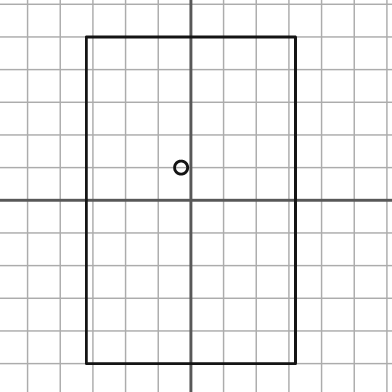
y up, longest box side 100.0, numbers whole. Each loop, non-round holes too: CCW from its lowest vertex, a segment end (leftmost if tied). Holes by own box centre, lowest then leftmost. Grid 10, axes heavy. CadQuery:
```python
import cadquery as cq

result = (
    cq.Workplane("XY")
    .moveTo(-32.0, -50.0)
    .lineTo(32.0, -50.0)
    .lineTo(32.0, 50.0)
    .lineTo(-32.0, 50.0)
    .close()
    .moveTo(-3.0, 10.0)
    .circle(2.0)
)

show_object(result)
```